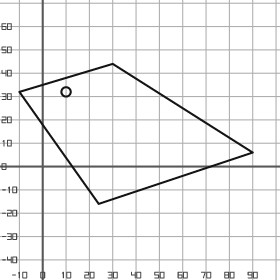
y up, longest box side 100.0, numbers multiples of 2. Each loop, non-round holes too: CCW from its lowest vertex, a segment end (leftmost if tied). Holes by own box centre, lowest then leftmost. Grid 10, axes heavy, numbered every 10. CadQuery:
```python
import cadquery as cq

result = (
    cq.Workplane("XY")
    .moveTo(24.0, -16.0)
    .lineTo(90.0, 6.0)
    .lineTo(30.0, 44.0)
    .lineTo(-10.0, 32.0)
    .close()
    .moveTo(10.0, 32.0)
    .circle(2.0)
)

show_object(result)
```